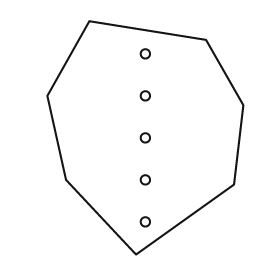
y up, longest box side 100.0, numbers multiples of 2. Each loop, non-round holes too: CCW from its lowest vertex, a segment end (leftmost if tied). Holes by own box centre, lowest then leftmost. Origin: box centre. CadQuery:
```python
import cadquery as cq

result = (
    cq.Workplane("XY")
    .moveTo(-4.0, -50.0)
    .lineTo(38.0, -20.0)
    .lineTo(42.0, 14.0)
    .lineTo(26.0, 42.0)
    .lineTo(-24.0, 50.0)
    .lineTo(-42.0, 18.0)
    .lineTo(-34.0, -18.0)
    .close()
    .moveTo(0.0, -36.0)
    .circle(2.0)
    .moveTo(0.0, -18.0)
    .circle(2.0)
    .moveTo(0.0, 0.0)
    .circle(2.0)
    .moveTo(0.0, 18.0)
    .circle(2.0)
    .moveTo(0.0, 36.0)
    .circle(2.0)
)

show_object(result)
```